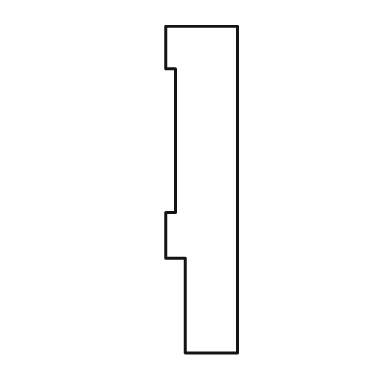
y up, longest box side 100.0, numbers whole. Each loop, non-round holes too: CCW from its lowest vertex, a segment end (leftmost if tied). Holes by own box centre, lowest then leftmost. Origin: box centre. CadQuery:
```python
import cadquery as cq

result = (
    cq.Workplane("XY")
    .moveTo(-5.0, -50.0)
    .lineTo(11.0, -50.0)
    .lineTo(11.0, 50.0)
    .lineTo(-11.0, 50.0)
    .lineTo(-11.0, 37.0)
    .lineTo(-8.0, 37.0)
    .lineTo(-8.0, -7.0)
    .lineTo(-11.0, -7.0)
    .lineTo(-11.0, -21.0)
    .lineTo(-5.0, -21.0)
    .close()
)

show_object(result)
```